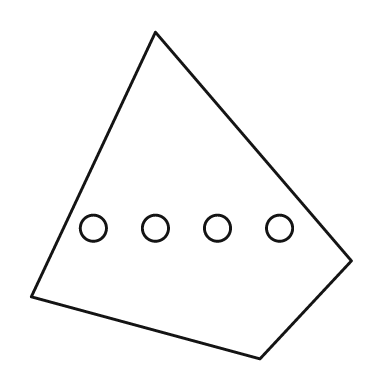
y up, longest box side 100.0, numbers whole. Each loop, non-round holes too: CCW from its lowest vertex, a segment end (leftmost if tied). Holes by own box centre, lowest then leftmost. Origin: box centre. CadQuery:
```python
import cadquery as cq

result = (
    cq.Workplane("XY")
    .moveTo(21.0, -50.0)
    .lineTo(49.0, -20.0)
    .lineTo(-11.0, 50.0)
    .lineTo(-49.0, -31.0)
    .close()
    .moveTo(-30.0, -10.0)
    .circle(4.0)
    .moveTo(-11.0, -10.0)
    .circle(4.0)
    .moveTo(8.0, -10.0)
    .circle(4.0)
    .moveTo(27.0, -10.0)
    .circle(4.0)
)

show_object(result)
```